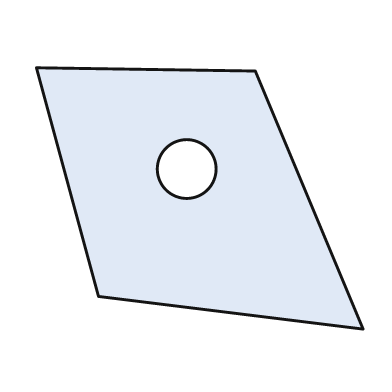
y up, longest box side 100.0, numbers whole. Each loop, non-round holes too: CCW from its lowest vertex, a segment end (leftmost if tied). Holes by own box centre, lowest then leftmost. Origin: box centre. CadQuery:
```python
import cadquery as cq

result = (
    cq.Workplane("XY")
    .moveTo(50.0, -40.0)
    .lineTo(17.0, 39.0)
    .lineTo(-50.0, 40.0)
    .lineTo(-31.0, -30.0)
    .close()
    .moveTo(-4.0, 9.0)
    .circle(9.0)
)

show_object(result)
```